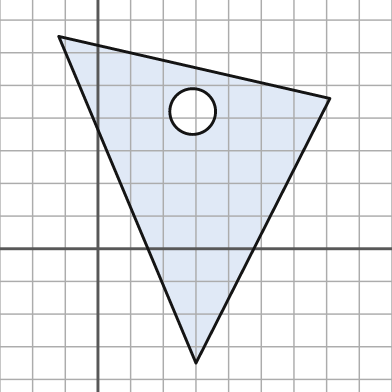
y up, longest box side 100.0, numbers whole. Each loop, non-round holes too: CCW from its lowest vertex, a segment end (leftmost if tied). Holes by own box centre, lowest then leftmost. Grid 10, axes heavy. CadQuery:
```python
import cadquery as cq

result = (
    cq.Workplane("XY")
    .moveTo(30.0, -35.0)
    .lineTo(71.0, 46.0)
    .lineTo(-12.0, 65.0)
    .close()
    .moveTo(29.0, 42.0)
    .circle(7.0)
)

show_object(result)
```